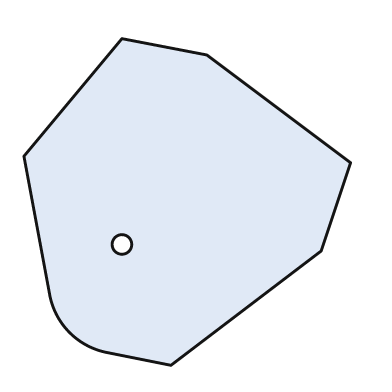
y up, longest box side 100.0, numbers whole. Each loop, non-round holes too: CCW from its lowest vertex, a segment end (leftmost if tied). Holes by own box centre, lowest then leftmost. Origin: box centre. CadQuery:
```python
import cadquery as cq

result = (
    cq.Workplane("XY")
    .moveTo(-5.0, -50.0)
    .lineTo(41.0, -15.0)
    .lineTo(50.0, 12.0)
    .lineTo(6.0, 45.0)
    .lineTo(-20.0, 50.0)
    .lineTo(-50.0, 14.0)
    .lineTo(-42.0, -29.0)
    .threePointArc((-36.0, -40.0), (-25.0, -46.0))
    .close()
    .moveTo(-20.0, -13.0)
    .circle(3.0)
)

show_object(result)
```